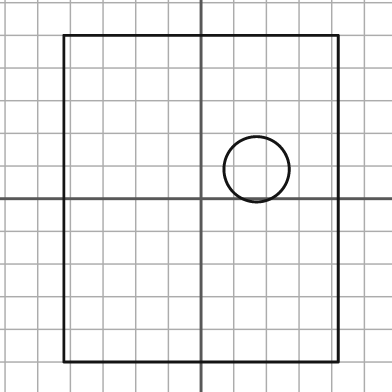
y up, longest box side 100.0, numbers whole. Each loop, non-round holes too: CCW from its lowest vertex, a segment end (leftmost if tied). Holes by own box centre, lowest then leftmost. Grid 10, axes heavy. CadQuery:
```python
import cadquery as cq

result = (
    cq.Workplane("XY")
    .moveTo(-42.0, -50.0)
    .lineTo(42.0, -50.0)
    .lineTo(42.0, 50.0)
    .lineTo(-42.0, 50.0)
    .close()
    .moveTo(17.0, 9.0)
    .circle(10.0)
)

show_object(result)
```